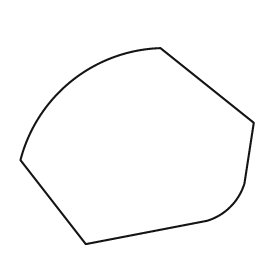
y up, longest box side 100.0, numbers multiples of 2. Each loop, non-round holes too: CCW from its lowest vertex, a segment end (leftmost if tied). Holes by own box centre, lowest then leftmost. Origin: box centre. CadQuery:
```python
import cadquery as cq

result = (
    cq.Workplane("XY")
    .moveTo(-22.0, -42.0)
    .lineTo(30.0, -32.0)
    .threePointArc((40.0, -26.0), (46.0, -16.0))
    .lineTo(50.0, 10.0)
    .lineTo(10.0, 42.0)
    .threePointArc((-28.0, 28.0), (-50.0, -6.0))
    .close()
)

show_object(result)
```